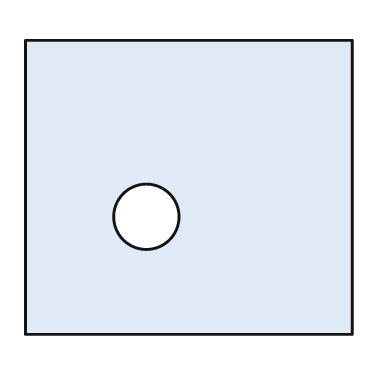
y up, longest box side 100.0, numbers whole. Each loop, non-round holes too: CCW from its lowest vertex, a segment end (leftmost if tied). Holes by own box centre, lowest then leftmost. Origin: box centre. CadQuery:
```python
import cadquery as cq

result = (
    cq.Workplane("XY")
    .moveTo(-50.0, -45.0)
    .lineTo(50.0, -45.0)
    .lineTo(50.0, 45.0)
    .lineTo(-50.0, 45.0)
    .close()
    .moveTo(-13.0, -9.0)
    .circle(10.0)
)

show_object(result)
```